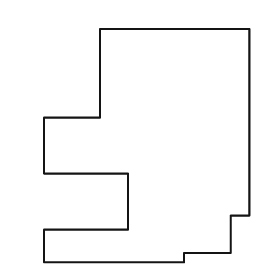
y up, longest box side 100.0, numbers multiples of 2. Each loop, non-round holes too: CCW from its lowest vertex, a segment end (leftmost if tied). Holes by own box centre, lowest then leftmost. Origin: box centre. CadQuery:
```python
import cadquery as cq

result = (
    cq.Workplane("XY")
    .moveTo(-44.0, -50.0)
    .lineTo(16.0, -50.0)
    .lineTo(16.0, -46.0)
    .lineTo(36.0, -46.0)
    .lineTo(36.0, -30.0)
    .lineTo(44.0, -30.0)
    .lineTo(44.0, 50.0)
    .lineTo(-20.0, 50.0)
    .lineTo(-20.0, 12.0)
    .lineTo(-44.0, 12.0)
    .lineTo(-44.0, -12.0)
    .lineTo(-8.0, -12.0)
    .lineTo(-8.0, -36.0)
    .lineTo(-44.0, -36.0)
    .close()
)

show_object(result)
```